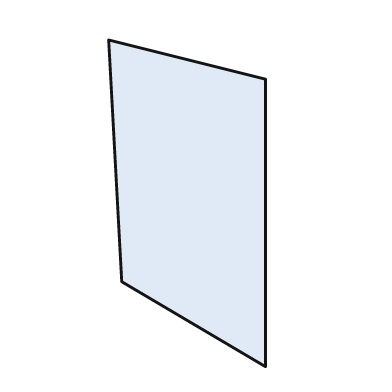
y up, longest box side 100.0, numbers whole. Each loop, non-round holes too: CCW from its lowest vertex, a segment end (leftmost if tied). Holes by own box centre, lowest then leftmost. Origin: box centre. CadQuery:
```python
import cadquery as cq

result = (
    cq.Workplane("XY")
    .moveTo(24.0, -50.0)
    .lineTo(24.0, 38.0)
    .lineTo(-24.0, 50.0)
    .lineTo(-20.0, -24.0)
    .close()
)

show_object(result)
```